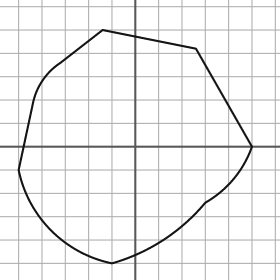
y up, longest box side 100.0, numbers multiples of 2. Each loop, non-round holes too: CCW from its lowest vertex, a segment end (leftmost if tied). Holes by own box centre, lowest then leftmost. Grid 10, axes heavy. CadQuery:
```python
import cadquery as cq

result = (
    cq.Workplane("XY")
    .moveTo(-10.0, -50.0)
    .threePointArc((12.0, -40.0), (30.0, -24.0))
    .threePointArc((42.0, -14.0), (50.0, 0.0))
    .lineTo(26.0, 42.0)
    .lineTo(-14.0, 50.0)
    .lineTo(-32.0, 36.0)
    .threePointArc((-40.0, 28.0), (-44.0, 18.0))
    .lineTo(-50.0, -10.0)
    .threePointArc((-36.0, -36.0), (-10.0, -50.0))
    .close()
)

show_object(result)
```